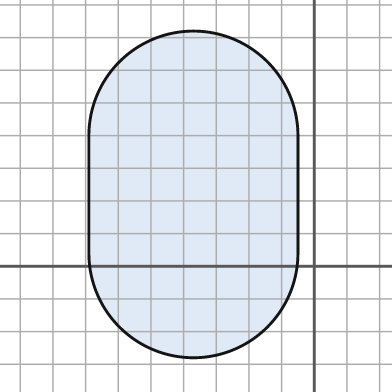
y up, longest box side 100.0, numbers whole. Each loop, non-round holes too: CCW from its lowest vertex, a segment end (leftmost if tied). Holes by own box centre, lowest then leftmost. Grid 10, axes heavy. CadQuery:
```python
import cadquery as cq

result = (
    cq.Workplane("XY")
    .moveTo(-69.0, 4.0)
    .threePointArc((-37.0, -28.0), (-5.0, 4.0))
    .lineTo(-5.0, 40.0)
    .threePointArc((-37.0, 72.0), (-69.0, 40.0))
    .close()
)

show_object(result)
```